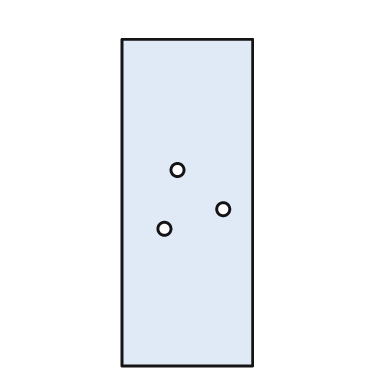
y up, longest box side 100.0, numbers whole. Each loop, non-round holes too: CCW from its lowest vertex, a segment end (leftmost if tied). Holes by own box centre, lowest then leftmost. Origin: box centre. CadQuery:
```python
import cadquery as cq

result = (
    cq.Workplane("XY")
    .moveTo(-20.0, -50.0)
    .lineTo(20.0, -50.0)
    .lineTo(20.0, 50.0)
    .lineTo(-20.0, 50.0)
    .close()
    .moveTo(-7.0, -8.0)
    .circle(2.0)
    .moveTo(11.0, -2.0)
    .circle(2.0)
    .moveTo(-3.0, 10.0)
    .circle(2.0)
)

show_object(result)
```